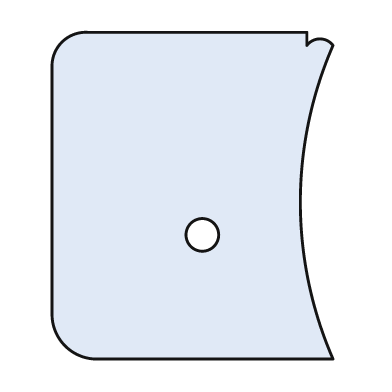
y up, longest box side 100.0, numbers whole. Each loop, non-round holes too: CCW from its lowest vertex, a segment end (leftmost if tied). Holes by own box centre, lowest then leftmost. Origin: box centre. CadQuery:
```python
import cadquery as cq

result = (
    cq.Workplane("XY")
    .moveTo(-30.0, -50.0)
    .lineTo(43.0, -50.0)
    .threePointArc((33.0, -2.0), (43.0, 46.0))
    .threePointArc((39.0, 48.0), (35.0, 46.0))
    .lineTo(35.0, 50.0)
    .lineTo(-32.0, 50.0)
    .threePointArc((-40.0, 47.0), (-43.0, 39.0))
    .lineTo(-43.0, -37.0)
    .threePointArc((-39.0, -46.0), (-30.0, -50.0))
    .close()
    .moveTo(3.0, -12.0)
    .circle(5.0)
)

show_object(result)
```